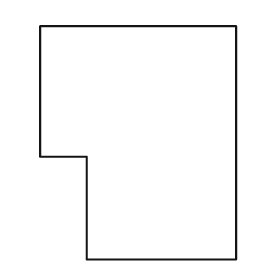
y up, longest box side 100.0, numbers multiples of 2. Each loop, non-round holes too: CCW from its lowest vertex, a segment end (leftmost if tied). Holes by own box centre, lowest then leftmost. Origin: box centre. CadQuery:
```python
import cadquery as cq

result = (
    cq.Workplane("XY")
    .moveTo(-22.0, -50.0)
    .lineTo(42.0, -50.0)
    .lineTo(42.0, 50.0)
    .lineTo(-42.0, 50.0)
    .lineTo(-42.0, -6.0)
    .lineTo(-22.0, -6.0)
    .close()
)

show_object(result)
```